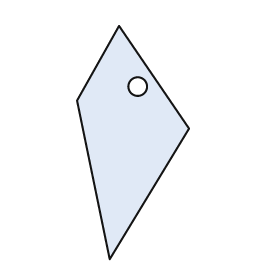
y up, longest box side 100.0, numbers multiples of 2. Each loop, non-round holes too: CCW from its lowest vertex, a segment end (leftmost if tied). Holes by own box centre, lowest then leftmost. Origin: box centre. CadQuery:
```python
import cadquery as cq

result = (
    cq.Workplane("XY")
    .moveTo(-10.0, -50.0)
    .lineTo(24.0, 6.0)
    .lineTo(-6.0, 50.0)
    .lineTo(-24.0, 18.0)
    .close()
    .moveTo(2.0, 24.0)
    .circle(4.0)
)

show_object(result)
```